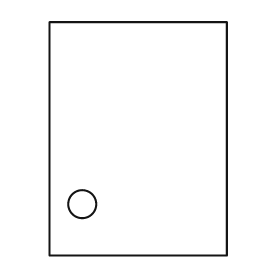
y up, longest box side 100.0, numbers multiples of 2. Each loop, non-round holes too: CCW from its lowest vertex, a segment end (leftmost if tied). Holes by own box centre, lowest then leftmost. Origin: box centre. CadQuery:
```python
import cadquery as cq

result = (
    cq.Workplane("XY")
    .moveTo(-38.0, -50.0)
    .lineTo(38.0, -50.0)
    .lineTo(38.0, 50.0)
    .lineTo(-38.0, 50.0)
    .close()
    .moveTo(-24.0, -28.0)
    .circle(6.0)
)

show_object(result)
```